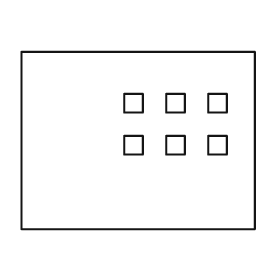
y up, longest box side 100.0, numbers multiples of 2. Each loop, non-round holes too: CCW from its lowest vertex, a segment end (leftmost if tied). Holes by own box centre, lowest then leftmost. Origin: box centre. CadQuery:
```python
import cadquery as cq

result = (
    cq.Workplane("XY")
    .moveTo(-50.0, -38.0)
    .lineTo(50.0, -38.0)
    .lineTo(50.0, 38.0)
    .lineTo(-50.0, 38.0)
    .close()
    .moveTo(-6.0, -6.0)
    .lineTo(2.0, -6.0)
    .lineTo(2.0, 2.0)
    .lineTo(-6.0, 2.0)
    .close()
    .moveTo(12.0, -6.0)
    .lineTo(20.0, -6.0)
    .lineTo(20.0, 2.0)
    .lineTo(12.0, 2.0)
    .close()
    .moveTo(30.0, -6.0)
    .lineTo(38.0, -6.0)
    .lineTo(38.0, 2.0)
    .lineTo(30.0, 2.0)
    .close()
    .moveTo(-6.0, 12.0)
    .lineTo(2.0, 12.0)
    .lineTo(2.0, 20.0)
    .lineTo(-6.0, 20.0)
    .close()
    .moveTo(12.0, 12.0)
    .lineTo(20.0, 12.0)
    .lineTo(20.0, 20.0)
    .lineTo(12.0, 20.0)
    .close()
    .moveTo(30.0, 12.0)
    .lineTo(38.0, 12.0)
    .lineTo(38.0, 20.0)
    .lineTo(30.0, 20.0)
    .close()
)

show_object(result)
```